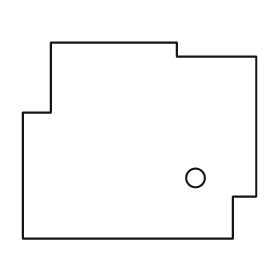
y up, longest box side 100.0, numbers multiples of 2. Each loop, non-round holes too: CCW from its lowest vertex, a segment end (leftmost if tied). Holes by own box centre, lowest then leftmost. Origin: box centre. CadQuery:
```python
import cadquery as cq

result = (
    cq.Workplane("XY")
    .moveTo(-50.0, -42.0)
    .lineTo(40.0, -42.0)
    .lineTo(40.0, -24.0)
    .lineTo(50.0, -24.0)
    .lineTo(50.0, 36.0)
    .lineTo(16.0, 36.0)
    .lineTo(16.0, 42.0)
    .lineTo(-38.0, 42.0)
    .lineTo(-38.0, 12.0)
    .lineTo(-50.0, 12.0)
    .close()
    .moveTo(24.0, -16.0)
    .circle(4.0)
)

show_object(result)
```